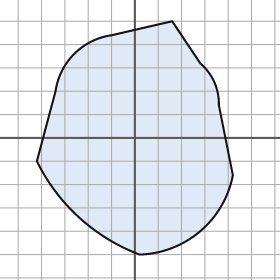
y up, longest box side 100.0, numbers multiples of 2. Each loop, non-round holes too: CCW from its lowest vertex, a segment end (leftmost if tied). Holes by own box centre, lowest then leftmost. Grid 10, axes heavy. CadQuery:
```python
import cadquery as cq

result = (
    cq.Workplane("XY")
    .moveTo(2.0, -50.0)
    .threePointArc((28.0, -40.0), (42.0, -16.0))
    .lineTo(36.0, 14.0)
    .threePointArc((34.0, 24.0), (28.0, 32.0))
    .lineTo(16.0, 50.0)
    .lineTo(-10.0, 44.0)
    .threePointArc((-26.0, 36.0), (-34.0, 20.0))
    .lineTo(-42.0, -10.0)
    .threePointArc((-24.0, -34.0), (2.0, -50.0))
    .close()
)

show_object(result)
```